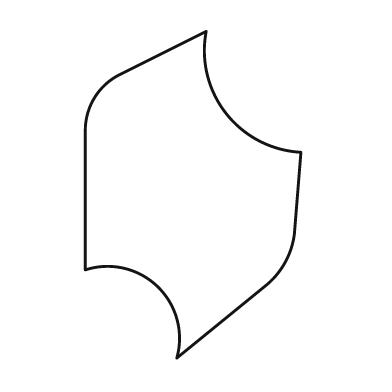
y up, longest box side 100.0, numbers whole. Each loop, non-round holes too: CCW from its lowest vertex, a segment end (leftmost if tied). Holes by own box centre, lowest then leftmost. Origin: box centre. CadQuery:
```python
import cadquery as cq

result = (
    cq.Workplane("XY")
    .moveTo(-5.0, -50.0)
    .lineTo(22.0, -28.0)
    .threePointArc((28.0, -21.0), (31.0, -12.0))
    .lineTo(33.0, 13.0)
    .threePointArc((10.0, 25.0), (4.0, 50.0))
    .lineTo(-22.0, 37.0)
    .threePointArc((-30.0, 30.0), (-33.0, 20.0))
    .lineTo(-33.0, -23.0)
    .threePointArc((-11.0, -28.0), (-5.0, -50.0))
    .close()
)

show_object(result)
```